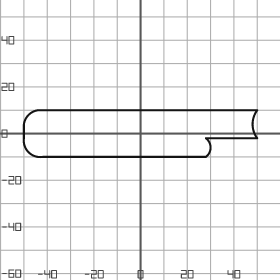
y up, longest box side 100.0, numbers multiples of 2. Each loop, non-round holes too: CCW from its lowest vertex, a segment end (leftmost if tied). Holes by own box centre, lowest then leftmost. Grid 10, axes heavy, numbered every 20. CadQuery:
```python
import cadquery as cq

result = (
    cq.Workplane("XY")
    .moveTo(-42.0, -10.0)
    .lineTo(28.0, -10.0)
    .threePointArc((30.0, -6.0), (28.0, -2.0))
    .lineTo(50.0, -2.0)
    .threePointArc((48.0, 4.0), (50.0, 10.0))
    .lineTo(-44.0, 10.0)
    .threePointArc((-48.0, 8.0), (-50.0, 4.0))
    .lineTo(-50.0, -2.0)
    .threePointArc((-48.0, -8.0), (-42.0, -10.0))
    .close()
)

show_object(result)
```